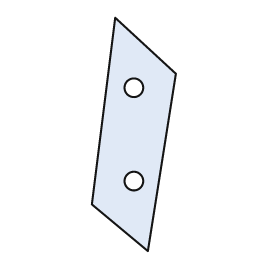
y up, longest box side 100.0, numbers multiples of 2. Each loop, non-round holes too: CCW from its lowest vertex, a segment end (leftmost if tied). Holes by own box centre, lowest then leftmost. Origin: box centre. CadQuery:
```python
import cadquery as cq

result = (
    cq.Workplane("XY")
    .moveTo(6.0, -50.0)
    .lineTo(18.0, 26.0)
    .lineTo(-8.0, 50.0)
    .lineTo(-18.0, -30.0)
    .close()
    .moveTo(0.0, -20.0)
    .circle(4.0)
    .moveTo(0.0, 20.0)
    .circle(4.0)
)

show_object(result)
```